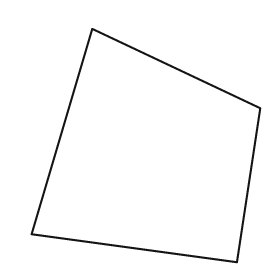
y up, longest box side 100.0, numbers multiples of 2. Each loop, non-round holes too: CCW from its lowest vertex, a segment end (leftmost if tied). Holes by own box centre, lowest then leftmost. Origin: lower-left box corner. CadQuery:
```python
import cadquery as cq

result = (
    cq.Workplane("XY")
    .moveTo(88.0, 0.0)
    .lineTo(98.0, 66.0)
    .lineTo(26.0, 100.0)
    .lineTo(0.0, 12.0)
    .close()
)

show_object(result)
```